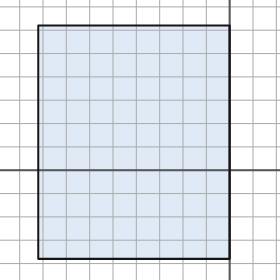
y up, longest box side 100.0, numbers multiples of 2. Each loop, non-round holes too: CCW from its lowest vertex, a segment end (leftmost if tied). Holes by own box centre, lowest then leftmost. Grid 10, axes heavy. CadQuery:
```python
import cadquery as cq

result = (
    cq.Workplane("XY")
    .moveTo(-82.0, -38.0)
    .lineTo(0.0, -38.0)
    .lineTo(0.0, 62.0)
    .lineTo(-82.0, 62.0)
    .close()
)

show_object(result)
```